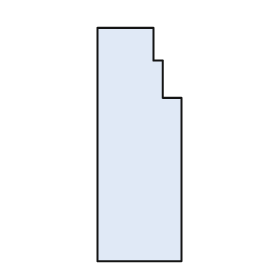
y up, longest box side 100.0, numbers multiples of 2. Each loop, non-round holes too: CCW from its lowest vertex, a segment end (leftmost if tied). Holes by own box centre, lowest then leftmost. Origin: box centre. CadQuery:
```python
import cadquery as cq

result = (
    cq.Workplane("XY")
    .moveTo(-18.0, -50.0)
    .lineTo(18.0, -50.0)
    .lineTo(18.0, 20.0)
    .lineTo(10.0, 20.0)
    .lineTo(10.0, 36.0)
    .lineTo(6.0, 36.0)
    .lineTo(6.0, 50.0)
    .lineTo(-18.0, 50.0)
    .close()
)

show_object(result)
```